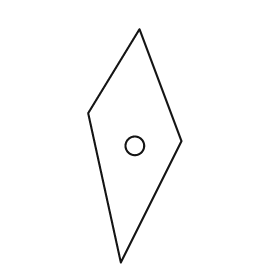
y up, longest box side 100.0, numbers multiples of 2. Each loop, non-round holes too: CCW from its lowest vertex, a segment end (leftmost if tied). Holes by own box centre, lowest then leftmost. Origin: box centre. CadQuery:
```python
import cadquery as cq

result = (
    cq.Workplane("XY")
    .moveTo(-6.0, -50.0)
    .lineTo(20.0, 2.0)
    .lineTo(2.0, 50.0)
    .lineTo(-20.0, 14.0)
    .close()
    .moveTo(0.0, 0.0)
    .circle(4.0)
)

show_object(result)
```